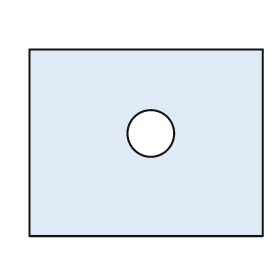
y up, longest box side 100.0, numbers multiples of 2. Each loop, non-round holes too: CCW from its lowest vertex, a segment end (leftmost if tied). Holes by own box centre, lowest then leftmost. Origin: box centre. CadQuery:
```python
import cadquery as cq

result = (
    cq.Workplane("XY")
    .moveTo(-50.0, -40.0)
    .lineTo(50.0, -40.0)
    .lineTo(50.0, 40.0)
    .lineTo(-50.0, 40.0)
    .close()
    .moveTo(2.0, 4.0)
    .circle(10.0)
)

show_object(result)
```